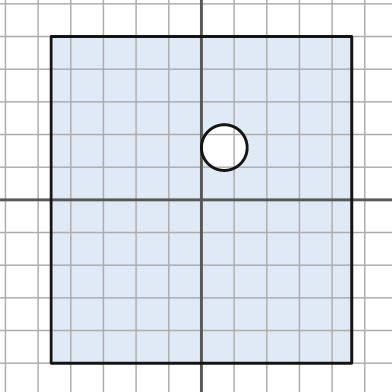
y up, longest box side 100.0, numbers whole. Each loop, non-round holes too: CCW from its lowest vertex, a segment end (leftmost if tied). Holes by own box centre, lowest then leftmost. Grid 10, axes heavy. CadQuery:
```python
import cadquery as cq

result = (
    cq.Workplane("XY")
    .moveTo(-46.0, -50.0)
    .lineTo(46.0, -50.0)
    .lineTo(46.0, 50.0)
    .lineTo(-46.0, 50.0)
    .close()
    .moveTo(7.0, 16.0)
    .circle(7.0)
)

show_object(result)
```